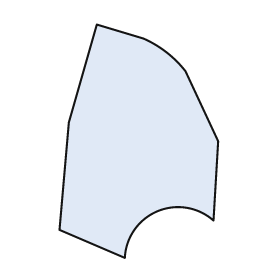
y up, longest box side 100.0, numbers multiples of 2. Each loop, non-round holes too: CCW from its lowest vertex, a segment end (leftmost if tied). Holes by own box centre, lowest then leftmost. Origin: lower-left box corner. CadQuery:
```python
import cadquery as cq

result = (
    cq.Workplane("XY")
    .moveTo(28.0, 0.0)
    .threePointArc((42.0, 20.0), (66.0, 16.0))
    .lineTo(68.0, 50.0)
    .lineTo(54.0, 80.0)
    .threePointArc((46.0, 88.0), (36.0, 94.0))
    .lineTo(16.0, 100.0)
    .lineTo(4.0, 58.0)
    .lineTo(0.0, 12.0)
    .close()
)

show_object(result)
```